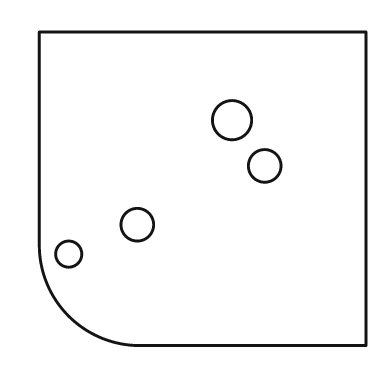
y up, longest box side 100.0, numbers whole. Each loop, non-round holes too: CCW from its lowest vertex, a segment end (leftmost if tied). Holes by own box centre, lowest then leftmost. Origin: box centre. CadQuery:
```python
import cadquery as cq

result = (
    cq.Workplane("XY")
    .moveTo(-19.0, -48.0)
    .lineTo(50.0, -48.0)
    .lineTo(50.0, 48.0)
    .lineTo(-50.0, 48.0)
    .lineTo(-50.0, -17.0)
    .threePointArc((-41.0, -39.0), (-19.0, -48.0))
    .close()
    .moveTo(-41.0, -20.0)
    .circle(4.0)
    .moveTo(-20.0, -11.0)
    .circle(5.0)
    .moveTo(19.0, 7.0)
    .circle(5.0)
    .moveTo(9.0, 21.0)
    .circle(6.0)
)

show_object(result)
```